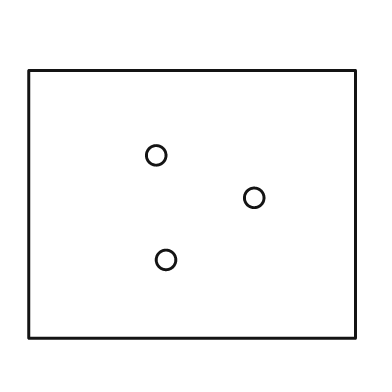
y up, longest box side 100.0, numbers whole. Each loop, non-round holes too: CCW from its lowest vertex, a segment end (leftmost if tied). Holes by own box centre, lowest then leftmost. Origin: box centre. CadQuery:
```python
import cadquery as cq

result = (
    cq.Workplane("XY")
    .moveTo(-50.0, -41.0)
    .lineTo(50.0, -41.0)
    .lineTo(50.0, 41.0)
    .lineTo(-50.0, 41.0)
    .close()
    .moveTo(-8.0, -17.0)
    .circle(3.0)
    .moveTo(19.0, 2.0)
    .circle(3.0)
    .moveTo(-11.0, 15.0)
    .circle(3.0)
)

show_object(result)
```